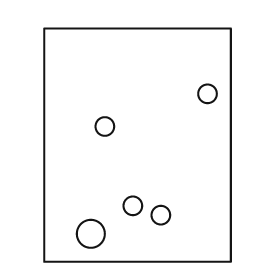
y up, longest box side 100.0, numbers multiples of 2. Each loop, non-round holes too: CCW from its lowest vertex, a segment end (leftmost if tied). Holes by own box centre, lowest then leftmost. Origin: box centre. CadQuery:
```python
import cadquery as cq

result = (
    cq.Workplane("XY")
    .moveTo(-40.0, -50.0)
    .lineTo(40.0, -50.0)
    .lineTo(40.0, 50.0)
    .lineTo(-40.0, 50.0)
    .close()
    .moveTo(-20.0, -38.0)
    .circle(6.0)
    .moveTo(10.0, -30.0)
    .circle(4.0)
    .moveTo(-2.0, -26.0)
    .circle(4.0)
    .moveTo(-14.0, 8.0)
    .circle(4.0)
    .moveTo(30.0, 22.0)
    .circle(4.0)
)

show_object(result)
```